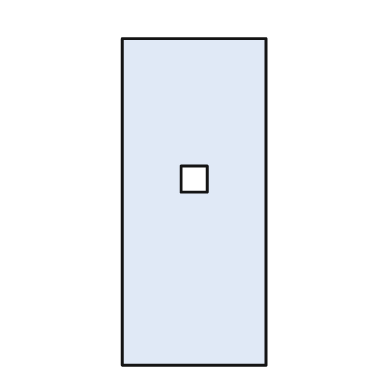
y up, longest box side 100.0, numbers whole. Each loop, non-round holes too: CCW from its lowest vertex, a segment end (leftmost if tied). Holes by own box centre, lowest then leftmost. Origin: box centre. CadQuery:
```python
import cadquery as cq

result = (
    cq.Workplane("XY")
    .moveTo(-22.0, -50.0)
    .lineTo(22.0, -50.0)
    .lineTo(22.0, 50.0)
    .lineTo(-22.0, 50.0)
    .close()
    .moveTo(-4.0, 3.0)
    .lineTo(4.0, 3.0)
    .lineTo(4.0, 11.0)
    .lineTo(-4.0, 11.0)
    .close()
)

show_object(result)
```